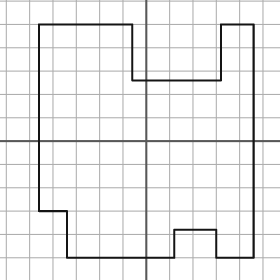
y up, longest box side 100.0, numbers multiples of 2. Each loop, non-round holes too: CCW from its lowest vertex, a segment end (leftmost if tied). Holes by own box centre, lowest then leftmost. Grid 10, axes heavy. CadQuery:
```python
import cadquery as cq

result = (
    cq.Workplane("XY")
    .moveTo(-34.0, -50.0)
    .lineTo(12.0, -50.0)
    .lineTo(12.0, -38.0)
    .lineTo(30.0, -38.0)
    .lineTo(30.0, -50.0)
    .lineTo(46.0, -50.0)
    .lineTo(46.0, 50.0)
    .lineTo(32.0, 50.0)
    .lineTo(32.0, 26.0)
    .lineTo(-6.0, 26.0)
    .lineTo(-6.0, 50.0)
    .lineTo(-46.0, 50.0)
    .lineTo(-46.0, -30.0)
    .lineTo(-34.0, -30.0)
    .close()
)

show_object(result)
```